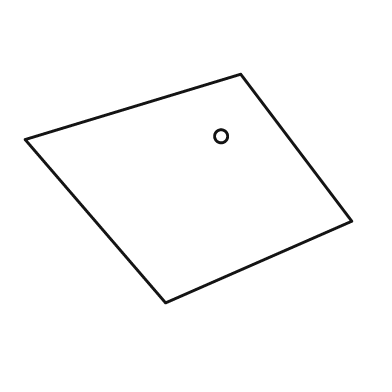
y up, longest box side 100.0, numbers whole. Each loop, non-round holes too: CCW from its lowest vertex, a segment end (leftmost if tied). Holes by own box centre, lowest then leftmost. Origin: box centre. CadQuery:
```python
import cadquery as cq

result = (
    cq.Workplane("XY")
    .moveTo(-7.0, -35.0)
    .lineTo(50.0, -10.0)
    .lineTo(16.0, 35.0)
    .lineTo(-50.0, 15.0)
    .close()
    .moveTo(10.0, 16.0)
    .circle(2.0)
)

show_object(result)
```